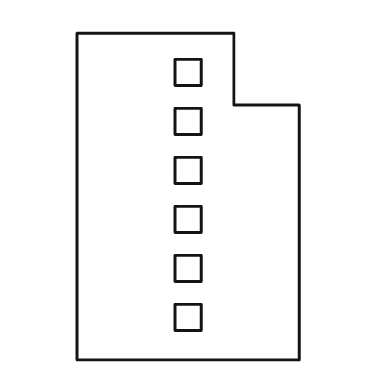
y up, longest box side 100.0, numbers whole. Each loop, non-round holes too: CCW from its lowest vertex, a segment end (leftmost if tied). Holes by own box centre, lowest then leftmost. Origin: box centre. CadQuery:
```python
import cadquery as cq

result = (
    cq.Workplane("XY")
    .moveTo(-34.0, -50.0)
    .lineTo(34.0, -50.0)
    .lineTo(34.0, 28.0)
    .lineTo(14.0, 28.0)
    .lineTo(14.0, 50.0)
    .lineTo(-34.0, 50.0)
    .close()
    .moveTo(-4.0, -41.0)
    .lineTo(4.0, -41.0)
    .lineTo(4.0, -33.0)
    .lineTo(-4.0, -33.0)
    .close()
    .moveTo(-4.0, -26.0)
    .lineTo(4.0, -26.0)
    .lineTo(4.0, -18.0)
    .lineTo(-4.0, -18.0)
    .close()
    .moveTo(-4.0, -11.0)
    .lineTo(4.0, -11.0)
    .lineTo(4.0, -3.0)
    .lineTo(-4.0, -3.0)
    .close()
    .moveTo(-4.0, 4.0)
    .lineTo(4.0, 4.0)
    .lineTo(4.0, 12.0)
    .lineTo(-4.0, 12.0)
    .close()
    .moveTo(-4.0, 19.0)
    .lineTo(4.0, 19.0)
    .lineTo(4.0, 27.0)
    .lineTo(-4.0, 27.0)
    .close()
    .moveTo(-4.0, 34.0)
    .lineTo(4.0, 34.0)
    .lineTo(4.0, 42.0)
    .lineTo(-4.0, 42.0)
    .close()
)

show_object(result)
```